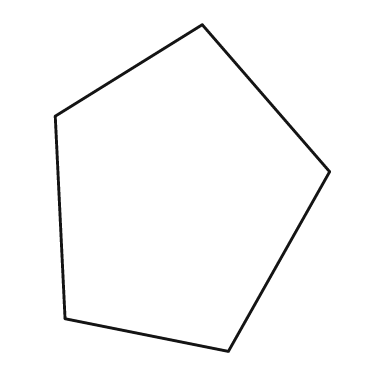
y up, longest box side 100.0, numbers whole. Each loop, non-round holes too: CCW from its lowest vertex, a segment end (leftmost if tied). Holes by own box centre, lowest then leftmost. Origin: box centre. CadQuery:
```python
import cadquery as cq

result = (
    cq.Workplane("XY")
    .moveTo(11.0, -50.0)
    .lineTo(42.0, 5.0)
    .lineTo(3.0, 50.0)
    .lineTo(-42.0, 22.0)
    .lineTo(-39.0, -40.0)
    .close()
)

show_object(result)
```